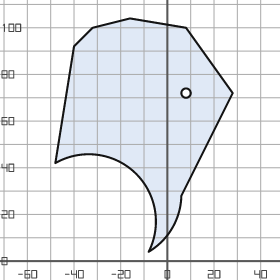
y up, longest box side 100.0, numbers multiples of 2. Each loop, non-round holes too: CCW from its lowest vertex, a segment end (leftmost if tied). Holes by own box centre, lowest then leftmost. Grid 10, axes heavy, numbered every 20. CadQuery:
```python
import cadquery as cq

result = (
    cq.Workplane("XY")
    .moveTo(-8.0, 4.0)
    .threePointArc((2.0, 14.0), (6.0, 28.0))
    .lineTo(28.0, 72.0)
    .lineTo(8.0, 100.0)
    .lineTo(-16.0, 104.0)
    .lineTo(-32.0, 100.0)
    .lineTo(-40.0, 92.0)
    .lineTo(-48.0, 42.0)
    .threePointArc((-14.0, 38.0), (-8.0, 4.0))
    .close()
    .moveTo(8.0, 72.0)
    .circle(2.0)
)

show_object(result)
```